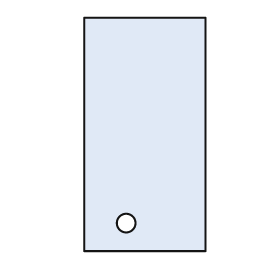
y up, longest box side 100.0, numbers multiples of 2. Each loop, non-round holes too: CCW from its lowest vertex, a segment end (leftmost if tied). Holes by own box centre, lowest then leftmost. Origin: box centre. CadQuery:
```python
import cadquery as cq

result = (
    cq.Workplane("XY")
    .moveTo(-26.0, -50.0)
    .lineTo(26.0, -50.0)
    .lineTo(26.0, 50.0)
    .lineTo(-26.0, 50.0)
    .close()
    .moveTo(-8.0, -38.0)
    .circle(4.0)
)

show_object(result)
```